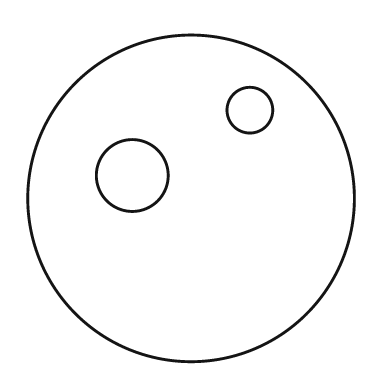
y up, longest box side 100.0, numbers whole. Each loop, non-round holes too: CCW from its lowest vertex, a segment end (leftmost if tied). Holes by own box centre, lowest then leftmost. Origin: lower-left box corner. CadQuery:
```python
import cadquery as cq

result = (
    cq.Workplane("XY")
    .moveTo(50.0, 50.0)
    .circle(50.0)
    .moveTo(32.0, 57.0)
    .circle(11.0)
    .moveTo(68.0, 77.0)
    .circle(7.0)
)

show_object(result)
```